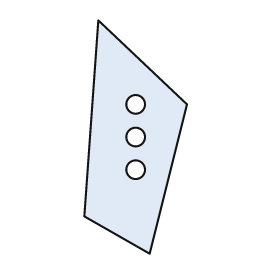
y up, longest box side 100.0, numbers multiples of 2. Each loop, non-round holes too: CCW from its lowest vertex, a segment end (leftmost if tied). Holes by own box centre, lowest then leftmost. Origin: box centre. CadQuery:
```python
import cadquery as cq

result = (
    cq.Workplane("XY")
    .moveTo(6.0, -50.0)
    .lineTo(22.0, 14.0)
    .lineTo(-16.0, 50.0)
    .lineTo(-22.0, -34.0)
    .close()
    .moveTo(0.0, -14.0)
    .circle(4.0)
    .moveTo(0.0, 0.0)
    .circle(4.0)
    .moveTo(0.0, 14.0)
    .circle(4.0)
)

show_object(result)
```